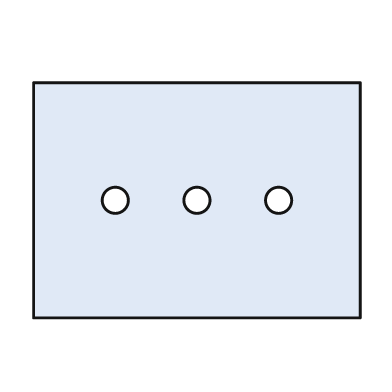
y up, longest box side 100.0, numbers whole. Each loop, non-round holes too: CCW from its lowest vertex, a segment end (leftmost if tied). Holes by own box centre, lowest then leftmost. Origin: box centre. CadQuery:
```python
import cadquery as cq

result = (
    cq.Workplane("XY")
    .moveTo(-50.0, -36.0)
    .lineTo(50.0, -36.0)
    .lineTo(50.0, 36.0)
    .lineTo(-50.0, 36.0)
    .close()
    .moveTo(-25.0, 0.0)
    .circle(4.0)
    .moveTo(0.0, 0.0)
    .circle(4.0)
    .moveTo(25.0, 0.0)
    .circle(4.0)
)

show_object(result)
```